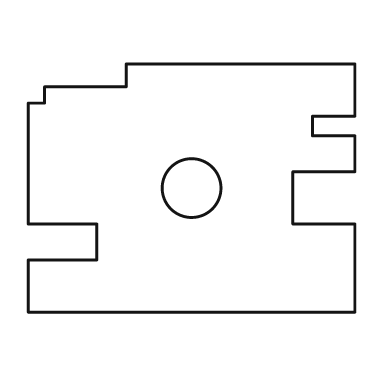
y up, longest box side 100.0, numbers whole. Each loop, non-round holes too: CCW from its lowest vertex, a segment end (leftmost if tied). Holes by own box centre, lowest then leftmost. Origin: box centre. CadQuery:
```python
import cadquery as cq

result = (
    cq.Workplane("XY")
    .moveTo(-50.0, -38.0)
    .lineTo(50.0, -38.0)
    .lineTo(50.0, -11.0)
    .lineTo(31.0, -11.0)
    .lineTo(31.0, 5.0)
    .lineTo(50.0, 5.0)
    .lineTo(50.0, 16.0)
    .lineTo(37.0, 16.0)
    .lineTo(37.0, 22.0)
    .lineTo(50.0, 22.0)
    .lineTo(50.0, 38.0)
    .lineTo(-20.0, 38.0)
    .lineTo(-20.0, 31.0)
    .lineTo(-45.0, 31.0)
    .lineTo(-45.0, 26.0)
    .lineTo(-50.0, 26.0)
    .lineTo(-50.0, -11.0)
    .lineTo(-29.0, -11.0)
    .lineTo(-29.0, -22.0)
    .lineTo(-50.0, -22.0)
    .close()
    .moveTo(0.0, 0.0)
    .circle(9.0)
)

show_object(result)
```